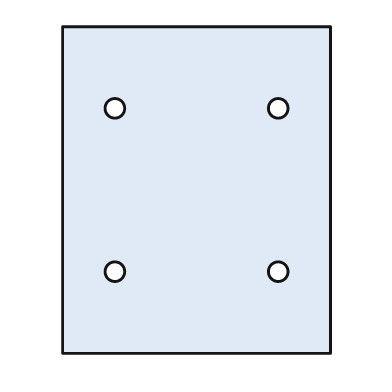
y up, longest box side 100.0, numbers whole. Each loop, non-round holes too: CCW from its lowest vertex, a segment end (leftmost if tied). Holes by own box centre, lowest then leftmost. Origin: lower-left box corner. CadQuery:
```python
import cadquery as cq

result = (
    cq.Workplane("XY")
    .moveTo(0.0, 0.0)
    .lineTo(82.0, 0.0)
    .lineTo(82.0, 100.0)
    .lineTo(0.0, 100.0)
    .close()
    .moveTo(16.0, 25.0)
    .circle(3.0)
    .moveTo(66.0, 25.0)
    .circle(3.0)
    .moveTo(16.0, 75.0)
    .circle(3.0)
    .moveTo(66.0, 75.0)
    .circle(3.0)
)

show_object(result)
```